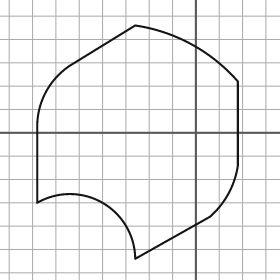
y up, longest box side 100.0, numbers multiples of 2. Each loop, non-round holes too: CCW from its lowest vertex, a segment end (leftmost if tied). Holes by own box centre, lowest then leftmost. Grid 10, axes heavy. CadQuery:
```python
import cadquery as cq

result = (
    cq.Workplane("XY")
    .moveTo(-26.0, -54.0)
    .lineTo(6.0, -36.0)
    .threePointArc((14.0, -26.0), (18.0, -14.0))
    .lineTo(18.0, 22.0)
    .threePointArc((-2.0, 38.0), (-26.0, 46.0))
    .lineTo(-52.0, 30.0)
    .threePointArc((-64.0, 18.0), (-68.0, 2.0))
    .lineTo(-68.0, -30.0)
    .threePointArc((-40.0, -30.0), (-26.0, -54.0))
    .close()
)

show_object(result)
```